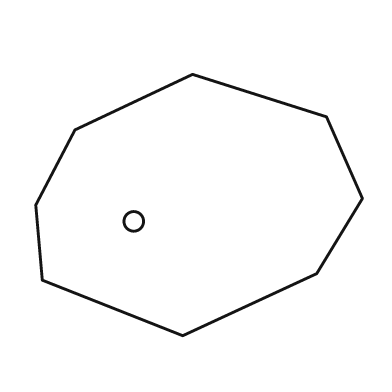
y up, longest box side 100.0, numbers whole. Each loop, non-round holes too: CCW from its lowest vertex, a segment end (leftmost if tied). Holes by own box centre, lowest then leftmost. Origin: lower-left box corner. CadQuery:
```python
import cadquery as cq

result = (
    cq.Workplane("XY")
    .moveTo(45.0, 0.0)
    .lineTo(86.0, 19.0)
    .lineTo(100.0, 42.0)
    .lineTo(89.0, 67.0)
    .lineTo(48.0, 80.0)
    .lineTo(12.0, 63.0)
    .lineTo(0.0, 40.0)
    .lineTo(2.0, 17.0)
    .close()
    .moveTo(30.0, 35.0)
    .circle(3.0)
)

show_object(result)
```